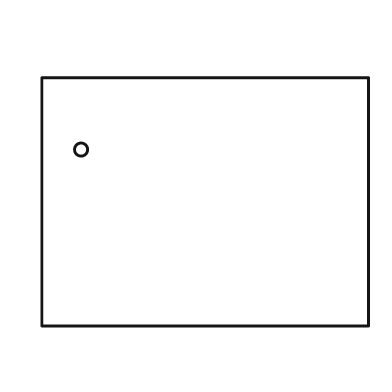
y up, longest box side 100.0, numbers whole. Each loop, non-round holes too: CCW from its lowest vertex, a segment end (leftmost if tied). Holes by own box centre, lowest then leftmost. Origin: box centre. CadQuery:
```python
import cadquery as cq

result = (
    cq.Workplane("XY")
    .moveTo(-50.0, -38.0)
    .lineTo(50.0, -38.0)
    .lineTo(50.0, 38.0)
    .lineTo(-50.0, 38.0)
    .close()
    .moveTo(-38.0, 16.0)
    .circle(2.0)
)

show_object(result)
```